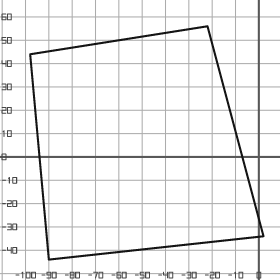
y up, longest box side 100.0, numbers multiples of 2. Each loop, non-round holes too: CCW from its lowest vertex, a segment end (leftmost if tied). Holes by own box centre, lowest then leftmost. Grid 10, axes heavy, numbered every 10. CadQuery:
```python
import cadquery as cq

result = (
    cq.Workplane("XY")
    .moveTo(-90.0, -44.0)
    .lineTo(2.0, -34.0)
    .lineTo(-22.0, 56.0)
    .lineTo(-98.0, 44.0)
    .close()
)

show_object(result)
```